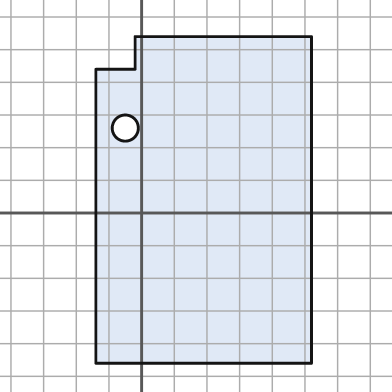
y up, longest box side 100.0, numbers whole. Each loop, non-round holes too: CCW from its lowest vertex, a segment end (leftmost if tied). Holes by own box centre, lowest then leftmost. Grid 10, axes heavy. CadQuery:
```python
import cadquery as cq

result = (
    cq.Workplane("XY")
    .moveTo(-14.0, -46.0)
    .lineTo(52.0, -46.0)
    .lineTo(52.0, 54.0)
    .lineTo(-2.0, 54.0)
    .lineTo(-2.0, 44.0)
    .lineTo(-14.0, 44.0)
    .close()
    .moveTo(-5.0, 26.0)
    .circle(4.0)
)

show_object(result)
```